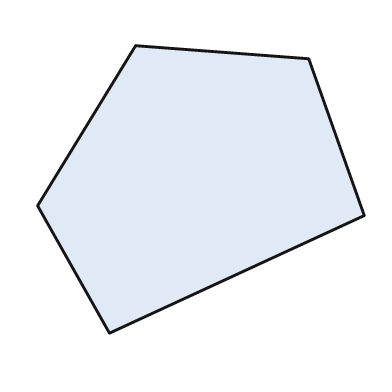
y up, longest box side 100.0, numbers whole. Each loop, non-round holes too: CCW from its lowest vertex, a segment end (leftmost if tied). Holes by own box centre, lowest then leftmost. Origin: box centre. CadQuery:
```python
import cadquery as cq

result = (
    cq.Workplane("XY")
    .moveTo(-28.0, -44.0)
    .lineTo(50.0, -8.0)
    .lineTo(33.0, 40.0)
    .lineTo(-20.0, 44.0)
    .lineTo(-50.0, -5.0)
    .close()
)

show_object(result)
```